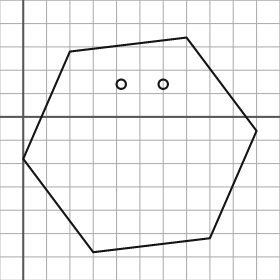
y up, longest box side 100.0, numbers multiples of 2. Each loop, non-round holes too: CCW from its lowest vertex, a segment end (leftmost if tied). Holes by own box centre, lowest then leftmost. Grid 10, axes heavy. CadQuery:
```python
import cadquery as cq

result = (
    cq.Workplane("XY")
    .moveTo(30.0, -58.0)
    .lineTo(80.0, -52.0)
    .lineTo(100.0, -6.0)
    .lineTo(70.0, 34.0)
    .lineTo(20.0, 28.0)
    .lineTo(0.0, -18.0)
    .close()
    .moveTo(42.0, 14.0)
    .circle(2.0)
    .moveTo(60.0, 14.0)
    .circle(2.0)
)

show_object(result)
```